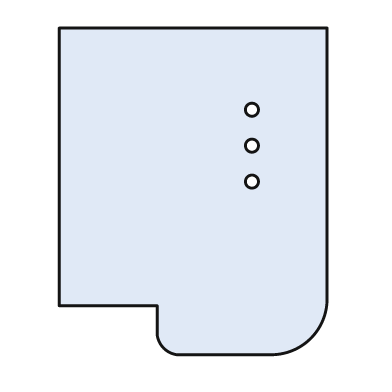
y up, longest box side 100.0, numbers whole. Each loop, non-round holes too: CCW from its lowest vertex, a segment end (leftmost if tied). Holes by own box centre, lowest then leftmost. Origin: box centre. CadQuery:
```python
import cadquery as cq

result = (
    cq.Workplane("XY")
    .moveTo(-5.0, -50.0)
    .lineTo(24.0, -50.0)
    .threePointArc((36.0, -45.0), (41.0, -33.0))
    .lineTo(41.0, 50.0)
    .lineTo(-41.0, 50.0)
    .lineTo(-41.0, -35.0)
    .lineTo(-11.0, -35.0)
    .lineTo(-11.0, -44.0)
    .threePointArc((-9.0, -48.0), (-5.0, -50.0))
    .close()
    .moveTo(18.0, 3.0)
    .circle(2.0)
    .moveTo(18.0, 14.0)
    .circle(2.0)
    .moveTo(18.0, 25.0)
    .circle(2.0)
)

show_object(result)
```